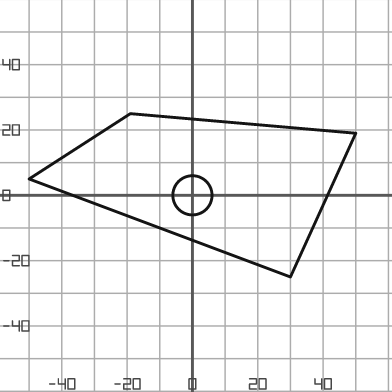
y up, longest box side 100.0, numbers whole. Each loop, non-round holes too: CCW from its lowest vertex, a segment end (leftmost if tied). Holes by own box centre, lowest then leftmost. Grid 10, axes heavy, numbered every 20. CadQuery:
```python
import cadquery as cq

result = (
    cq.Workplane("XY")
    .moveTo(30.0, -25.0)
    .lineTo(50.0, 19.0)
    .lineTo(-19.0, 25.0)
    .lineTo(-50.0, 5.0)
    .close()
    .moveTo(0.0, 0.0)
    .circle(6.0)
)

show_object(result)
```